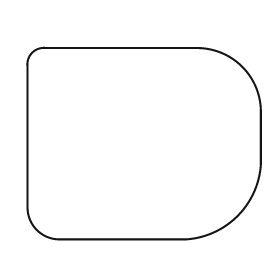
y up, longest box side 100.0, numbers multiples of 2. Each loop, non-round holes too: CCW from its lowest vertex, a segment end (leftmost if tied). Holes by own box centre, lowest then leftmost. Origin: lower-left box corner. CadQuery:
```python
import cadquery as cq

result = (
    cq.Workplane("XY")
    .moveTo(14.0, 0.0)
    .lineTo(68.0, 0.0)
    .threePointArc((90.0, 10.0), (100.0, 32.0))
    .lineTo(100.0, 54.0)
    .threePointArc((92.0, 74.0), (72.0, 82.0))
    .lineTo(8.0, 82.0)
    .threePointArc((2.0, 80.0), (0.0, 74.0))
    .lineTo(0.0, 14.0)
    .threePointArc((4.0, 4.0), (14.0, 0.0))
    .close()
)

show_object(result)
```